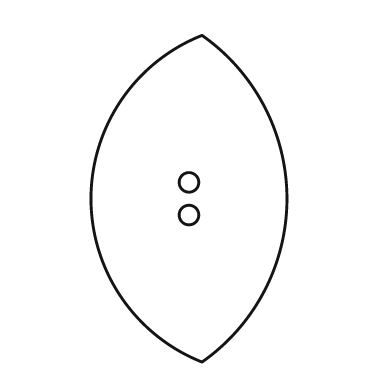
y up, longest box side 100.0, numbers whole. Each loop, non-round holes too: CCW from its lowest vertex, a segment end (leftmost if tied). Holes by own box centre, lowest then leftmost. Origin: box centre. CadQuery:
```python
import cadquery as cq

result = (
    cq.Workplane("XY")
    .moveTo(4.0, -50.0)
    .threePointArc((30.0, 0.0), (4.0, 50.0))
    .threePointArc((-30.0, 0.0), (4.0, -50.0))
    .close()
    .moveTo(0.0, -5.0)
    .circle(3.0)
    .moveTo(0.0, 5.0)
    .circle(3.0)
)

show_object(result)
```